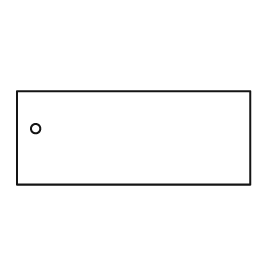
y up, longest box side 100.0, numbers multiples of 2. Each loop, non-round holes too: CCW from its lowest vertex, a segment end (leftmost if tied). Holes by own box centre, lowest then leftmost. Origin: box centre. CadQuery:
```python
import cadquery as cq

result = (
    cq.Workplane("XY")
    .moveTo(-50.0, -20.0)
    .lineTo(50.0, -20.0)
    .lineTo(50.0, 20.0)
    .lineTo(-50.0, 20.0)
    .close()
    .moveTo(-42.0, 4.0)
    .circle(2.0)
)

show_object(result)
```